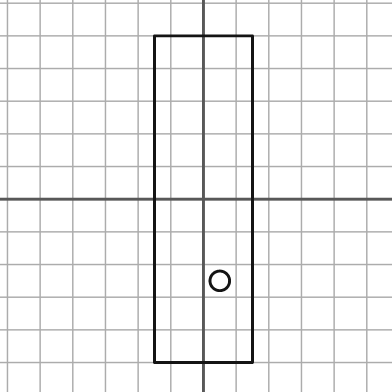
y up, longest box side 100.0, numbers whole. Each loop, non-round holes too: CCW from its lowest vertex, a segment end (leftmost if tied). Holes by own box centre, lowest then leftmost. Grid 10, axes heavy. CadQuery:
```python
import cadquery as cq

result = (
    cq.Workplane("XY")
    .moveTo(-15.0, -50.0)
    .lineTo(15.0, -50.0)
    .lineTo(15.0, 50.0)
    .lineTo(-15.0, 50.0)
    .close()
    .moveTo(5.0, -25.0)
    .circle(3.0)
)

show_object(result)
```